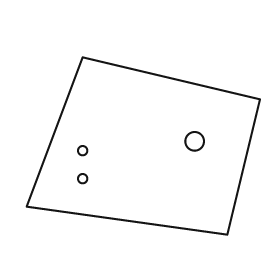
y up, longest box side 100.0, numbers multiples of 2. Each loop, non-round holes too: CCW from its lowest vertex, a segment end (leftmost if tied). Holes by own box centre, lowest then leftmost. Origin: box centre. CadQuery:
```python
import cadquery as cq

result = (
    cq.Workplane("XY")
    .moveTo(36.0, -38.0)
    .lineTo(50.0, 20.0)
    .lineTo(-26.0, 38.0)
    .lineTo(-50.0, -26.0)
    .close()
    .moveTo(-26.0, -14.0)
    .circle(2.0)
    .moveTo(-26.0, -2.0)
    .circle(2.0)
    .moveTo(22.0, 2.0)
    .circle(4.0)
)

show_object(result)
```